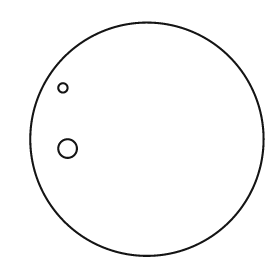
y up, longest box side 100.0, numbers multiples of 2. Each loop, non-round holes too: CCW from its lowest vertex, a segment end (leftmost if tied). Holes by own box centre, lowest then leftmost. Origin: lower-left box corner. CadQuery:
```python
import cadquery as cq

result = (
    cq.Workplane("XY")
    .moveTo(50.0, 50.0)
    .circle(50.0)
    .moveTo(16.0, 46.0)
    .circle(4.0)
    .moveTo(14.0, 72.0)
    .circle(2.0)
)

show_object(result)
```